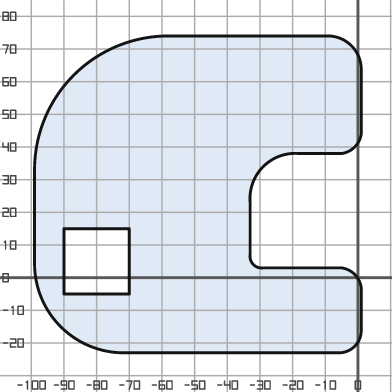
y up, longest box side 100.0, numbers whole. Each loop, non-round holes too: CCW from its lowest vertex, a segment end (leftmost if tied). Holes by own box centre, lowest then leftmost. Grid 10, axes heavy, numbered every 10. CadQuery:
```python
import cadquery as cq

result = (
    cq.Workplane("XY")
    .moveTo(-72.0, -23.0)
    .lineTo(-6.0, -23.0)
    .threePointArc((-1.0, -21.0), (1.0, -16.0))
    .lineTo(1.0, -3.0)
    .threePointArc((-1.0, 1.0), (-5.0, 3.0))
    .lineTo(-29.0, 3.0)
    .threePointArc((-32.0, 4.0), (-33.0, 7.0))
    .lineTo(-33.0, 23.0)
    .threePointArc((-29.0, 34.0), (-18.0, 38.0))
    .lineTo(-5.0, 38.0)
    .threePointArc((-1.0, 40.0), (1.0, 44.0))
    .lineTo(1.0, 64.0)
    .threePointArc((-2.0, 71.0), (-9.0, 74.0))
    .lineTo(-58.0, 74.0)
    .threePointArc((-87.0, 62.0), (-99.0, 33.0))
    .lineTo(-99.0, 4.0)
    .threePointArc((-91.0, -15.0), (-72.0, -23.0))
    .close()
    .moveTo(-90.0, -5.0)
    .lineTo(-70.0, -5.0)
    .lineTo(-70.0, 15.0)
    .lineTo(-90.0, 15.0)
    .close()
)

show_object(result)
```